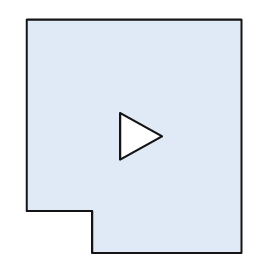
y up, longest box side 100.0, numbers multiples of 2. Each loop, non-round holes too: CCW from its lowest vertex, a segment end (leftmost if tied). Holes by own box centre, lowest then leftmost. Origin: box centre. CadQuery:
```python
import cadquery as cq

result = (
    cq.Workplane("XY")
    .moveTo(-18.0, -50.0)
    .lineTo(46.0, -50.0)
    .lineTo(46.0, 50.0)
    .lineTo(-46.0, 50.0)
    .lineTo(-46.0, -32.0)
    .lineTo(-18.0, -32.0)
    .close()
    .moveTo(-6.0, -10.0)
    .lineTo(12.0, 0.0)
    .lineTo(-6.0, 10.0)
    .close()
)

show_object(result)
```